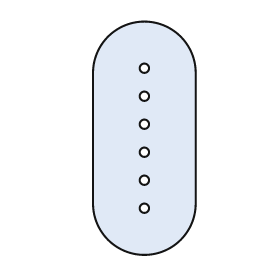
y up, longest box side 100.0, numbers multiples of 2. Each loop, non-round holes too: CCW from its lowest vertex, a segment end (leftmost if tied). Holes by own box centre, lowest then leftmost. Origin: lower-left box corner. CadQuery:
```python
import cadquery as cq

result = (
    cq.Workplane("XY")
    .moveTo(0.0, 22.0)
    .threePointArc((22.0, 0.0), (44.0, 22.0))
    .lineTo(44.0, 78.0)
    .threePointArc((22.0, 100.0), (0.0, 78.0))
    .close()
    .moveTo(22.0, 20.0)
    .circle(2.0)
    .moveTo(22.0, 32.0)
    .circle(2.0)
    .moveTo(22.0, 44.0)
    .circle(2.0)
    .moveTo(22.0, 56.0)
    .circle(2.0)
    .moveTo(22.0, 68.0)
    .circle(2.0)
    .moveTo(22.0, 80.0)
    .circle(2.0)
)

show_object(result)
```